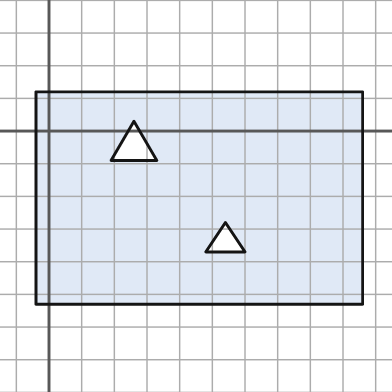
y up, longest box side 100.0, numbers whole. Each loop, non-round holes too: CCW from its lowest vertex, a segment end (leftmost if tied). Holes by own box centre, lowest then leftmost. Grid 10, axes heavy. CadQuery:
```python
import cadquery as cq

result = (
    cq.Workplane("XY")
    .moveTo(-4.0, -53.0)
    .lineTo(96.0, -53.0)
    .lineTo(96.0, 12.0)
    .lineTo(-4.0, 12.0)
    .close()
    .moveTo(48.0, -37.0)
    .lineTo(60.0, -37.0)
    .lineTo(54.0, -28.0)
    .close()
    .moveTo(19.0, -9.0)
    .lineTo(33.0, -9.0)
    .lineTo(26.0, 3.0)
    .close()
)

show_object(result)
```